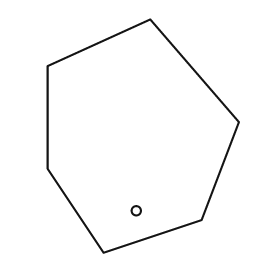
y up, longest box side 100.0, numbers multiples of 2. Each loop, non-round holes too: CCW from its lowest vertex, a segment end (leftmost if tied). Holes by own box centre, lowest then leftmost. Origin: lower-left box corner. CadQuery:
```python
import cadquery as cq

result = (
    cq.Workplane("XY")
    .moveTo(24.0, 0.0)
    .lineTo(66.0, 14.0)
    .lineTo(82.0, 56.0)
    .lineTo(44.0, 100.0)
    .lineTo(0.0, 80.0)
    .lineTo(0.0, 36.0)
    .close()
    .moveTo(38.0, 18.0)
    .circle(2.0)
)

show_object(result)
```